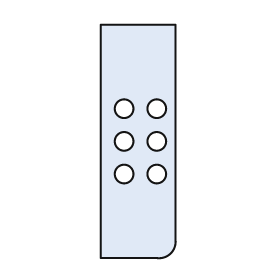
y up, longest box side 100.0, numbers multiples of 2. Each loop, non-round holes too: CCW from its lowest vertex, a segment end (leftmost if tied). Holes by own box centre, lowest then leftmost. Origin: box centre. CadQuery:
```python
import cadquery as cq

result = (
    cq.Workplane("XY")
    .moveTo(-16.0, -50.0)
    .lineTo(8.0, -50.0)
    .threePointArc((14.0, -48.0), (16.0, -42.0))
    .lineTo(16.0, 50.0)
    .lineTo(-16.0, 50.0)
    .close()
    .moveTo(-6.0, -14.0)
    .circle(4.0)
    .moveTo(8.0, -14.0)
    .circle(4.0)
    .moveTo(-6.0, 0.0)
    .circle(4.0)
    .moveTo(8.0, 0.0)
    .circle(4.0)
    .moveTo(-6.0, 14.0)
    .circle(4.0)
    .moveTo(8.0, 14.0)
    .circle(4.0)
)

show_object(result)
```